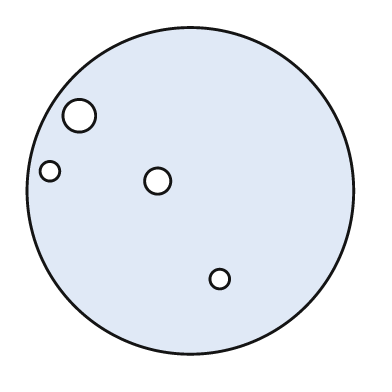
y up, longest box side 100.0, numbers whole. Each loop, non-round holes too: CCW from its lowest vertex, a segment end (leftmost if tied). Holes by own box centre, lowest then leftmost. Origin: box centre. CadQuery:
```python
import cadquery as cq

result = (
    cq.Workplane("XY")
    .moveTo(0.0, 0.0)
    .circle(50.0)
    .moveTo(9.0, -27.0)
    .circle(3.0)
    .moveTo(-10.0, 3.0)
    .circle(4.0)
    .moveTo(-43.0, 6.0)
    .circle(3.0)
    .moveTo(-34.0, 23.0)
    .circle(5.0)
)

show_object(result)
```